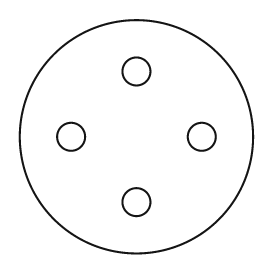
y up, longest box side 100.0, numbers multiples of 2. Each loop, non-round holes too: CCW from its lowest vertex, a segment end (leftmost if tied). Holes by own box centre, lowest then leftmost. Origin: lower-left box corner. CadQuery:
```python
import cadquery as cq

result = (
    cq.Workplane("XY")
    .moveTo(50.0, 50.0)
    .circle(50.0)
    .moveTo(50.0, 22.0)
    .circle(6.0)
    .moveTo(22.0, 50.0)
    .circle(6.0)
    .moveTo(78.0, 50.0)
    .circle(6.0)
    .moveTo(50.0, 78.0)
    .circle(6.0)
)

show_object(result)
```